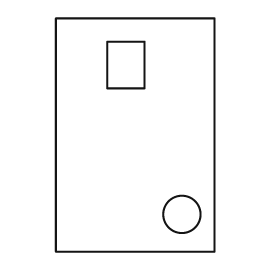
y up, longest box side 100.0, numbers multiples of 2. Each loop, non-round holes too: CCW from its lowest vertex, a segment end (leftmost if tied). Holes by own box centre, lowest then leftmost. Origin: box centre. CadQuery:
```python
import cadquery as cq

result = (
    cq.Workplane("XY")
    .moveTo(-34.0, -50.0)
    .lineTo(34.0, -50.0)
    .lineTo(34.0, 50.0)
    .lineTo(-34.0, 50.0)
    .close()
    .moveTo(20.0, -34.0)
    .circle(8.0)
    .moveTo(-12.0, 20.0)
    .lineTo(4.0, 20.0)
    .lineTo(4.0, 40.0)
    .lineTo(-12.0, 40.0)
    .close()
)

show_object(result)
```